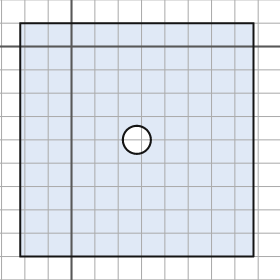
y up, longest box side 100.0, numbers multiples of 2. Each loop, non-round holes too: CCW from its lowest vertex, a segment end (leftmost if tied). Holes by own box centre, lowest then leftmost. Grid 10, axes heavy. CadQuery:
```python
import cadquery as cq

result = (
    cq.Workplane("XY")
    .moveTo(-22.0, -90.0)
    .lineTo(78.0, -90.0)
    .lineTo(78.0, 10.0)
    .lineTo(-22.0, 10.0)
    .close()
    .moveTo(28.0, -40.0)
    .circle(6.0)
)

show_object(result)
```